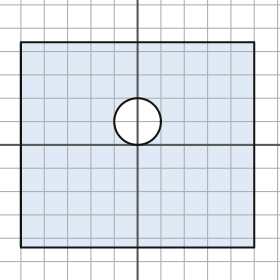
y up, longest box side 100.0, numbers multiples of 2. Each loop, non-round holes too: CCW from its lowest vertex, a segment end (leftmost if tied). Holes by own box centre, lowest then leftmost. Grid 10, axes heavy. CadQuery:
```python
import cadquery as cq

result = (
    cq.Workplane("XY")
    .moveTo(-50.0, -44.0)
    .lineTo(50.0, -44.0)
    .lineTo(50.0, 44.0)
    .lineTo(-50.0, 44.0)
    .close()
    .moveTo(0.0, 10.0)
    .circle(10.0)
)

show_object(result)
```